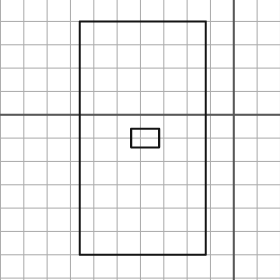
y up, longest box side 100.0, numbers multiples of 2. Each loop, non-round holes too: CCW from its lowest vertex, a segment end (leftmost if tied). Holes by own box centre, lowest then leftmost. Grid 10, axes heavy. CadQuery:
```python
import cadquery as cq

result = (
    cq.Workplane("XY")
    .moveTo(-66.0, -60.0)
    .lineTo(-12.0, -60.0)
    .lineTo(-12.0, 40.0)
    .lineTo(-66.0, 40.0)
    .close()
    .moveTo(-44.0, -14.0)
    .lineTo(-32.0, -14.0)
    .lineTo(-32.0, -6.0)
    .lineTo(-44.0, -6.0)
    .close()
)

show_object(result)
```